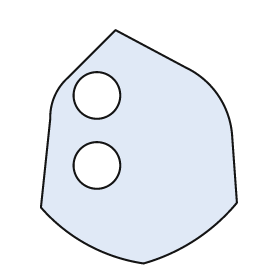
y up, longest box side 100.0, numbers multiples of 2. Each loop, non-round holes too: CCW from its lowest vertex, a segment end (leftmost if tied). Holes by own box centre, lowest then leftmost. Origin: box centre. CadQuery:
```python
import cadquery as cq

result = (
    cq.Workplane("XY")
    .moveTo(2.0, -50.0)
    .threePointArc((24.0, -40.0), (42.0, -24.0))
    .lineTo(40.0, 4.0)
    .threePointArc((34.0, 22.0), (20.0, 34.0))
    .lineTo(-10.0, 50.0)
    .lineTo(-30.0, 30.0)
    .threePointArc((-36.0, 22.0), (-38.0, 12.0))
    .lineTo(-42.0, -26.0)
    .threePointArc((-22.0, -42.0), (2.0, -50.0))
    .close()
    .moveTo(-18.0, -8.0)
    .circle(10.0)
    .moveTo(-18.0, 22.0)
    .circle(10.0)
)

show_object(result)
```